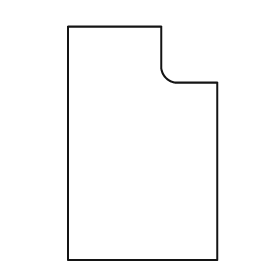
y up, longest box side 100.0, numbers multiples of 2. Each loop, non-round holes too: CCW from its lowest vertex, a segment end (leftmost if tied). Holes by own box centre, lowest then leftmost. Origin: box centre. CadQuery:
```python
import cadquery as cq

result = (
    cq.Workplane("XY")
    .moveTo(-32.0, -50.0)
    .lineTo(32.0, -50.0)
    .lineTo(32.0, 26.0)
    .lineTo(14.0, 26.0)
    .threePointArc((10.0, 28.0), (8.0, 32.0))
    .lineTo(8.0, 50.0)
    .lineTo(-32.0, 50.0)
    .close()
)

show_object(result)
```